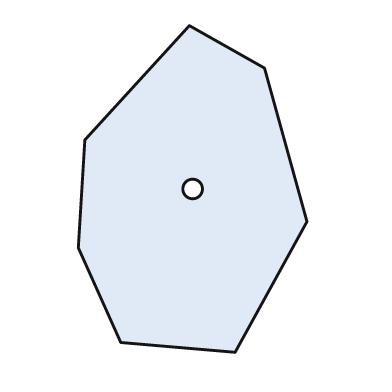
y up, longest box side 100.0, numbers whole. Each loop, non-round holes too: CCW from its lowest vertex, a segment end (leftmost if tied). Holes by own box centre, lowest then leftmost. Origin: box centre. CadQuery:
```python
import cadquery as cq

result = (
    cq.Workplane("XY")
    .moveTo(13.0, -50.0)
    .lineTo(35.0, -10.0)
    .lineTo(22.0, 37.0)
    .lineTo(-1.0, 50.0)
    .lineTo(-33.0, 15.0)
    .lineTo(-35.0, -18.0)
    .lineTo(-22.0, -47.0)
    .close()
    .moveTo(0.0, 0.0)
    .circle(3.0)
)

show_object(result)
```